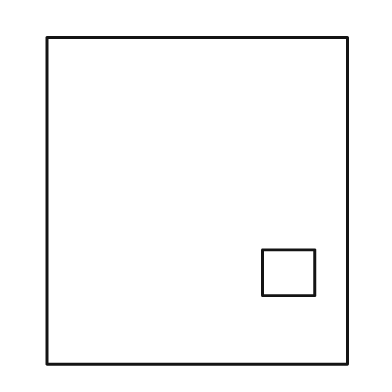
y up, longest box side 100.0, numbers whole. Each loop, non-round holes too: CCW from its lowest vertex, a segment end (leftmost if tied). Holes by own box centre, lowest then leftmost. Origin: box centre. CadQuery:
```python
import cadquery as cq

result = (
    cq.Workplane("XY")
    .moveTo(-46.0, -50.0)
    .lineTo(46.0, -50.0)
    .lineTo(46.0, 50.0)
    .lineTo(-46.0, 50.0)
    .close()
    .moveTo(20.0, -29.0)
    .lineTo(36.0, -29.0)
    .lineTo(36.0, -15.0)
    .lineTo(20.0, -15.0)
    .close()
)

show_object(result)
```